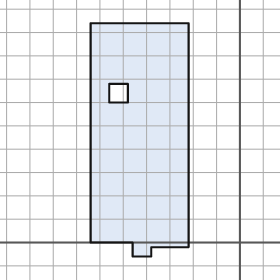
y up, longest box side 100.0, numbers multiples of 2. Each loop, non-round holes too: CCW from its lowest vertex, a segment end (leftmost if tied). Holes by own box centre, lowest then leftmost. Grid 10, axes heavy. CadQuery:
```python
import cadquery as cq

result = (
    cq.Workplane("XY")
    .moveTo(-46.0, -6.0)
    .lineTo(-38.0, -6.0)
    .lineTo(-38.0, -2.0)
    .lineTo(-22.0, -2.0)
    .lineTo(-22.0, 94.0)
    .lineTo(-64.0, 94.0)
    .lineTo(-64.0, 0.0)
    .lineTo(-46.0, 0.0)
    .close()
    .moveTo(-56.0, 60.0)
    .lineTo(-48.0, 60.0)
    .lineTo(-48.0, 68.0)
    .lineTo(-56.0, 68.0)
    .close()
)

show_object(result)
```